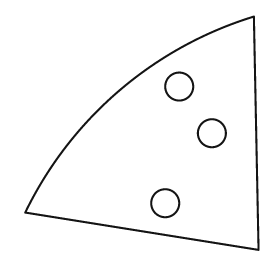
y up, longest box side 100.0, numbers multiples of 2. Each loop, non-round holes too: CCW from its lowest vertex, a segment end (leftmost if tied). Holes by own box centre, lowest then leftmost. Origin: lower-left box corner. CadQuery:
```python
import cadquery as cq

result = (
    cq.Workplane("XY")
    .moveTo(100.0, 0.0)
    .lineTo(98.0, 100.0)
    .threePointArc((40.0, 68.0), (0.0, 16.0))
    .close()
    .moveTo(60.0, 20.0)
    .circle(6.0)
    .moveTo(80.0, 50.0)
    .circle(6.0)
    .moveTo(66.0, 70.0)
    .circle(6.0)
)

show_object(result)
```